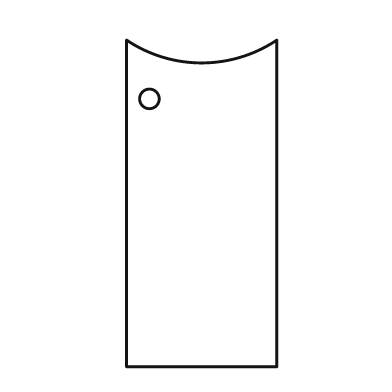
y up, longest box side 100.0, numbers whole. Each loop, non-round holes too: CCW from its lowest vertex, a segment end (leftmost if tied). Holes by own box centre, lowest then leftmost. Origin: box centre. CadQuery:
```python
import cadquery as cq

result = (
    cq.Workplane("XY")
    .moveTo(-23.0, -50.0)
    .lineTo(23.0, -50.0)
    .lineTo(23.0, 50.0)
    .threePointArc((0.0, 43.0), (-23.0, 50.0))
    .close()
    .moveTo(-16.0, 32.0)
    .circle(3.0)
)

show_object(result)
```